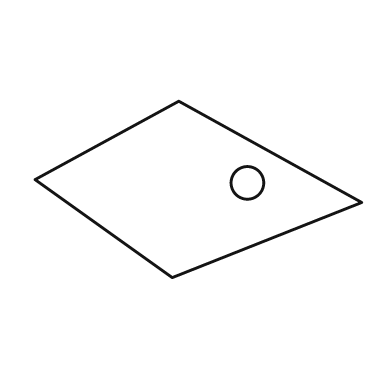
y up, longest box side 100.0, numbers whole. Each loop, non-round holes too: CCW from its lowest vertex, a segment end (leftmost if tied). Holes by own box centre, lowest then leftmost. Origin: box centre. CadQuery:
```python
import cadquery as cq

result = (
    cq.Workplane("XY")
    .moveTo(-8.0, -27.0)
    .lineTo(50.0, -4.0)
    .lineTo(-6.0, 27.0)
    .lineTo(-50.0, 3.0)
    .close()
    .moveTo(15.0, 2.0)
    .circle(5.0)
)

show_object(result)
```